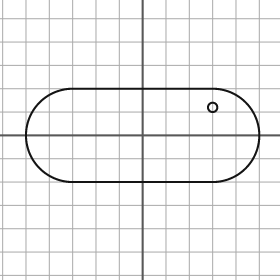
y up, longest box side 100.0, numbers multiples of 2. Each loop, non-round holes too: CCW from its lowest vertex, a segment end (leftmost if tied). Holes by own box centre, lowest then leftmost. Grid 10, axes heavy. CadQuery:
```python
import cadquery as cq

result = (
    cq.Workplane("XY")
    .moveTo(-30.0, -20.0)
    .lineTo(30.0, -20.0)
    .threePointArc((50.0, 0.0), (30.0, 20.0))
    .lineTo(-30.0, 20.0)
    .threePointArc((-50.0, 0.0), (-30.0, -20.0))
    .close()
    .moveTo(30.0, 12.0)
    .circle(2.0)
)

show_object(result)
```